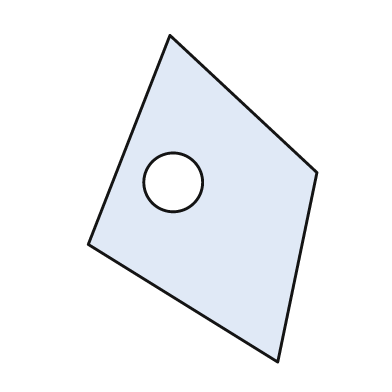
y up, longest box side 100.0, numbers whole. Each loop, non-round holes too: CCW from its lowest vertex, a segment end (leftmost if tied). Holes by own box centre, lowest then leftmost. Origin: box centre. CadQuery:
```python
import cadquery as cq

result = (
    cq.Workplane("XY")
    .moveTo(23.0, -50.0)
    .lineTo(35.0, 8.0)
    .lineTo(-10.0, 50.0)
    .lineTo(-35.0, -14.0)
    .close()
    .moveTo(-9.0, 5.0)
    .circle(9.0)
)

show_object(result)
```